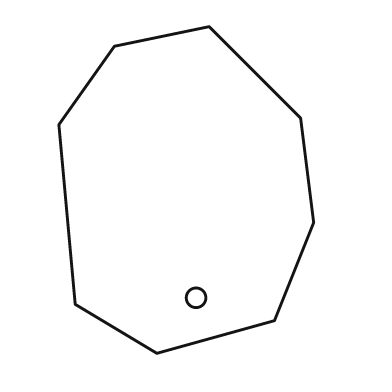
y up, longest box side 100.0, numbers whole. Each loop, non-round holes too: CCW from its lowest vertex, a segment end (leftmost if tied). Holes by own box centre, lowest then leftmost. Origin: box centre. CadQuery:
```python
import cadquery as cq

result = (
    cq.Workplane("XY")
    .moveTo(-9.0, -50.0)
    .lineTo(27.0, -40.0)
    .lineTo(39.0, -10.0)
    .lineTo(35.0, 22.0)
    .lineTo(7.0, 50.0)
    .lineTo(-22.0, 44.0)
    .lineTo(-39.0, 20.0)
    .lineTo(-34.0, -35.0)
    .close()
    .moveTo(3.0, -33.0)
    .circle(3.0)
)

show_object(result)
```